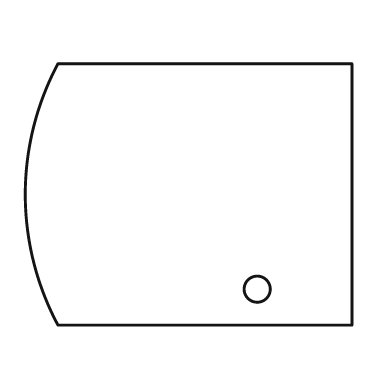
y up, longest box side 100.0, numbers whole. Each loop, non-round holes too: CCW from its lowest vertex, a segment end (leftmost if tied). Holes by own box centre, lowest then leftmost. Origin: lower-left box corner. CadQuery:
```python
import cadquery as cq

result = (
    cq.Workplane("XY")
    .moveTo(10.0, 0.0)
    .lineTo(100.0, 0.0)
    .lineTo(100.0, 80.0)
    .lineTo(10.0, 80.0)
    .threePointArc((0.0, 40.0), (10.0, 0.0))
    .close()
    .moveTo(71.0, 11.0)
    .circle(4.0)
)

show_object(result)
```